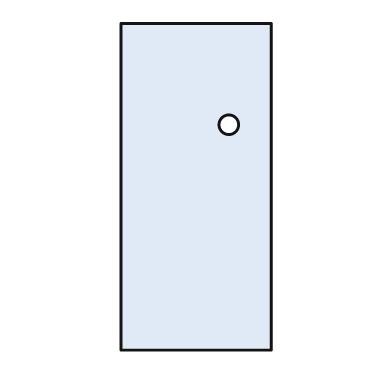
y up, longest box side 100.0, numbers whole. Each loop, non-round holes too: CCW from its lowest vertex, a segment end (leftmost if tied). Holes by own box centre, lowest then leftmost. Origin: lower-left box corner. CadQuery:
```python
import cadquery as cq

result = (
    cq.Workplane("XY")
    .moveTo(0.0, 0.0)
    .lineTo(46.0, 0.0)
    .lineTo(46.0, 100.0)
    .lineTo(0.0, 100.0)
    .close()
    .moveTo(33.0, 69.0)
    .circle(3.0)
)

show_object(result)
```